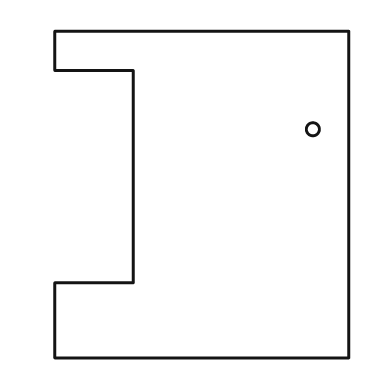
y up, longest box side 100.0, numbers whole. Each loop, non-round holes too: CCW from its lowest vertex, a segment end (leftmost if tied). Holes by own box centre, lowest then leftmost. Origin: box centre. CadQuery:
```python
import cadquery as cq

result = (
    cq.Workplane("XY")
    .moveTo(-45.0, -50.0)
    .lineTo(45.0, -50.0)
    .lineTo(45.0, 50.0)
    .lineTo(-45.0, 50.0)
    .lineTo(-45.0, 38.0)
    .lineTo(-21.0, 38.0)
    .lineTo(-21.0, -27.0)
    .lineTo(-45.0, -27.0)
    .close()
    .moveTo(34.0, 20.0)
    .circle(2.0)
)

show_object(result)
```